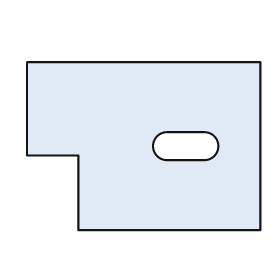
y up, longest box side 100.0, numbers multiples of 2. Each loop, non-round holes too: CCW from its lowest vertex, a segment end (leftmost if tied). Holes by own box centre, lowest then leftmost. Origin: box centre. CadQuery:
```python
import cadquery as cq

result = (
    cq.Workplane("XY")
    .moveTo(-28.0, -36.0)
    .lineTo(50.0, -36.0)
    .lineTo(50.0, 36.0)
    .lineTo(-50.0, 36.0)
    .lineTo(-50.0, -4.0)
    .lineTo(-28.0, -4.0)
    .close()
    .moveTo(10.0, -6.0)
    .lineTo(26.0, -6.0)
    .threePointArc((32.0, 0.0), (26.0, 6.0))
    .lineTo(10.0, 6.0)
    .threePointArc((4.0, 0.0), (10.0, -6.0))
    .close()
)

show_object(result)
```